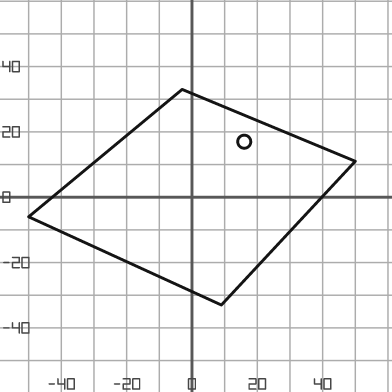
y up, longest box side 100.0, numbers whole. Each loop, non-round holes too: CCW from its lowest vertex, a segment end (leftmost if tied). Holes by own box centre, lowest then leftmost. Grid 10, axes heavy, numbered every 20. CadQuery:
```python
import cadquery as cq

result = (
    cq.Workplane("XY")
    .moveTo(9.0, -33.0)
    .lineTo(50.0, 11.0)
    .lineTo(-3.0, 33.0)
    .lineTo(-50.0, -6.0)
    .close()
    .moveTo(16.0, 17.0)
    .circle(2.0)
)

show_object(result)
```